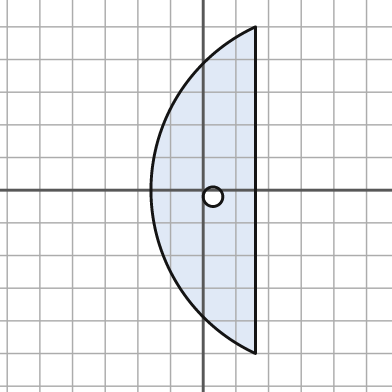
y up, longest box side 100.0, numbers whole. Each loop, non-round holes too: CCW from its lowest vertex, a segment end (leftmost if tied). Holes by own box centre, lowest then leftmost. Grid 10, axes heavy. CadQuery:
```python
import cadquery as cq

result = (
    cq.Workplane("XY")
    .moveTo(16.0, -50.0)
    .lineTo(16.0, 50.0)
    .threePointArc((-16.0, 0.0), (16.0, -50.0))
    .close()
    .moveTo(3.0, -2.0)
    .circle(3.0)
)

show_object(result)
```